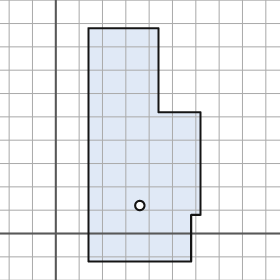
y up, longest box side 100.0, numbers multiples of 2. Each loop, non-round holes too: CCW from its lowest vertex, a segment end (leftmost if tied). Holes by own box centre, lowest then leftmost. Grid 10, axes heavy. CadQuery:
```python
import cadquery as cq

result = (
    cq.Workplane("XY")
    .moveTo(14.0, -12.0)
    .lineTo(58.0, -12.0)
    .lineTo(58.0, 8.0)
    .lineTo(62.0, 8.0)
    .lineTo(62.0, 52.0)
    .lineTo(44.0, 52.0)
    .lineTo(44.0, 88.0)
    .lineTo(14.0, 88.0)
    .close()
    .moveTo(36.0, 12.0)
    .circle(2.0)
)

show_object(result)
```